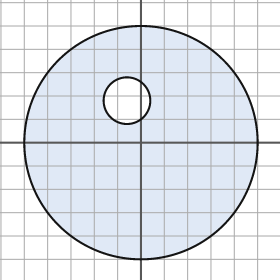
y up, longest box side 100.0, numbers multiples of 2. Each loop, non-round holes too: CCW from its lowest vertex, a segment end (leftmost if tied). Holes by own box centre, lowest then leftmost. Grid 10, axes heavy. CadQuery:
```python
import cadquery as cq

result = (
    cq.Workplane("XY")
    .moveTo(0.0, 0.0)
    .circle(50.0)
    .moveTo(-6.0, 18.0)
    .circle(10.0)
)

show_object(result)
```